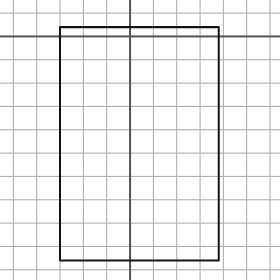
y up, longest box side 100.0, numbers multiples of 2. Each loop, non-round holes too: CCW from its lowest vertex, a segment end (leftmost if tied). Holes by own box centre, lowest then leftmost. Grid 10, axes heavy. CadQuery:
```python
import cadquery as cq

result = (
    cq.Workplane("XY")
    .moveTo(-30.0, -96.0)
    .lineTo(38.0, -96.0)
    .lineTo(38.0, 4.0)
    .lineTo(-30.0, 4.0)
    .close()
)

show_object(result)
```